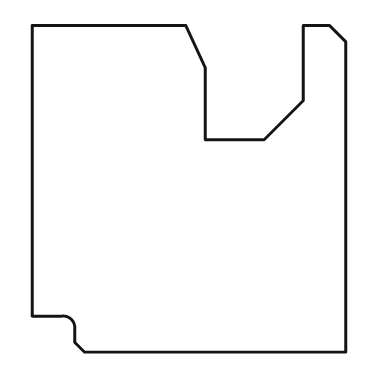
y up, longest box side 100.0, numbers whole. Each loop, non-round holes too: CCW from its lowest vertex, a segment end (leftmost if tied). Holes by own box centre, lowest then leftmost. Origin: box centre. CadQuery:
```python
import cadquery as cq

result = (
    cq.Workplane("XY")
    .moveTo(-32.0, -50.0)
    .lineTo(48.0, -50.0)
    .lineTo(48.0, 45.0)
    .lineTo(43.0, 50.0)
    .lineTo(35.0, 50.0)
    .lineTo(35.0, 27.0)
    .lineTo(23.0, 15.0)
    .lineTo(5.0, 15.0)
    .lineTo(5.0, 37.0)
    .lineTo(-1.0, 50.0)
    .lineTo(-48.0, 50.0)
    .lineTo(-48.0, -39.0)
    .lineTo(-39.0, -39.0)
    .threePointArc((-36.0, -40.0), (-35.0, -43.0))
    .lineTo(-35.0, -47.0)
    .close()
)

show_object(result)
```